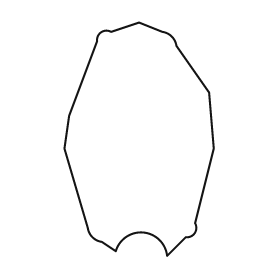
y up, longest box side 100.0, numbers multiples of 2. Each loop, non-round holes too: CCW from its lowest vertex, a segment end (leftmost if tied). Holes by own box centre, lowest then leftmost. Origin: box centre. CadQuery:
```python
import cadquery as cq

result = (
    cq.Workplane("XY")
    .moveTo(12.0, -50.0)
    .lineTo(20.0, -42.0)
    .threePointArc((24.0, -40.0), (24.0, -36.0))
    .lineTo(32.0, -4.0)
    .lineTo(30.0, 20.0)
    .lineTo(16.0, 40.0)
    .threePointArc((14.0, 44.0), (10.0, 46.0))
    .lineTo(0.0, 50.0)
    .lineTo(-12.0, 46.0)
    .threePointArc((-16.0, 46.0), (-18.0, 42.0))
    .lineTo(-30.0, 10.0)
    .lineTo(-32.0, -4.0)
    .lineTo(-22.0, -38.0)
    .threePointArc((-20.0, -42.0), (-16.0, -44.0))
    .lineTo(-10.0, -48.0)
    .threePointArc((2.0, -40.0), (12.0, -50.0))
    .close()
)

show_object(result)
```